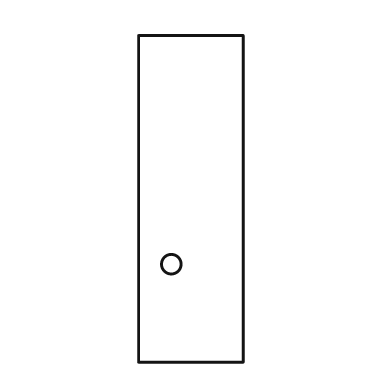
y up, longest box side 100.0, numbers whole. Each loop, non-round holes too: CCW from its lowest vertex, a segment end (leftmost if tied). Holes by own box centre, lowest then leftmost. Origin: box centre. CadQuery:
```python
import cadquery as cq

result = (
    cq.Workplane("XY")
    .moveTo(-16.0, -50.0)
    .lineTo(16.0, -50.0)
    .lineTo(16.0, 50.0)
    .lineTo(-16.0, 50.0)
    .close()
    .moveTo(-6.0, -20.0)
    .circle(3.0)
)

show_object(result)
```